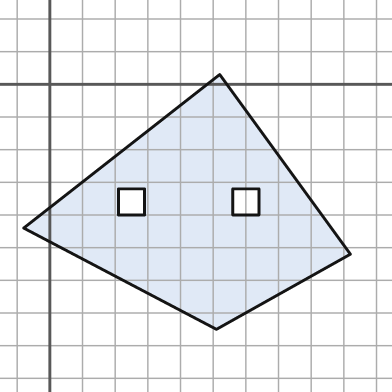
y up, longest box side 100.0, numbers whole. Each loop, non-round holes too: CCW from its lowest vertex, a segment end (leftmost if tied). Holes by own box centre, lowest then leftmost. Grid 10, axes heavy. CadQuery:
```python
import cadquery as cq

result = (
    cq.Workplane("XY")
    .moveTo(51.0, -75.0)
    .lineTo(92.0, -52.0)
    .lineTo(52.0, 3.0)
    .lineTo(-8.0, -44.0)
    .close()
    .moveTo(21.0, -40.0)
    .lineTo(29.0, -40.0)
    .lineTo(29.0, -32.0)
    .lineTo(21.0, -32.0)
    .close()
    .moveTo(56.0, -40.0)
    .lineTo(64.0, -40.0)
    .lineTo(64.0, -32.0)
    .lineTo(56.0, -32.0)
    .close()
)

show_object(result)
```